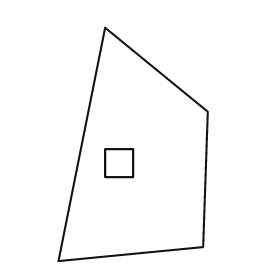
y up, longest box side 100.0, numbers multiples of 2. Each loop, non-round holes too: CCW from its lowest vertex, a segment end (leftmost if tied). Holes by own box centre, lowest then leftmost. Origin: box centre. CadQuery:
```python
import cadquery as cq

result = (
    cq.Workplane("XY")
    .moveTo(-32.0, -50.0)
    .lineTo(30.0, -44.0)
    .lineTo(32.0, 14.0)
    .lineTo(-12.0, 50.0)
    .close()
    .moveTo(-12.0, -14.0)
    .lineTo(0.0, -14.0)
    .lineTo(0.0, -2.0)
    .lineTo(-12.0, -2.0)
    .close()
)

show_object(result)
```